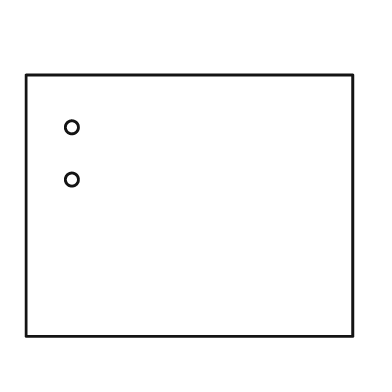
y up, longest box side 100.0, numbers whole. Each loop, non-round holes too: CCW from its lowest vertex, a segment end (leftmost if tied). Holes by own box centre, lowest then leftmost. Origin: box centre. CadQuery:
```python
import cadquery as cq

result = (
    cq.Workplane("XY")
    .moveTo(-50.0, -40.0)
    .lineTo(50.0, -40.0)
    .lineTo(50.0, 40.0)
    .lineTo(-50.0, 40.0)
    .close()
    .moveTo(-36.0, 8.0)
    .circle(2.0)
    .moveTo(-36.0, 24.0)
    .circle(2.0)
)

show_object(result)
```